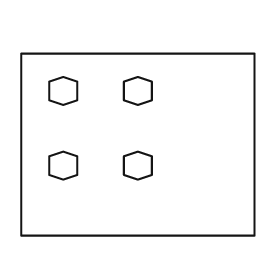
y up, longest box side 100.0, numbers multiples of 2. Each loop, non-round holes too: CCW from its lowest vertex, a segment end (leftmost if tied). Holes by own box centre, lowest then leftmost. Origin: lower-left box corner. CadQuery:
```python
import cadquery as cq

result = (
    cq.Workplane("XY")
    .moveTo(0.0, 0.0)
    .lineTo(100.0, 0.0)
    .lineTo(100.0, 78.0)
    .lineTo(0.0, 78.0)
    .close()
    .moveTo(18.0, 24.0)
    .lineTo(24.0, 26.0)
    .lineTo(24.0, 34.0)
    .lineTo(18.0, 36.0)
    .lineTo(12.0, 34.0)
    .lineTo(12.0, 26.0)
    .close()
    .moveTo(50.0, 24.0)
    .lineTo(56.0, 26.0)
    .lineTo(56.0, 34.0)
    .lineTo(50.0, 36.0)
    .lineTo(44.0, 34.0)
    .lineTo(44.0, 26.0)
    .close()
    .moveTo(18.0, 56.0)
    .lineTo(24.0, 58.0)
    .lineTo(24.0, 66.0)
    .lineTo(18.0, 68.0)
    .lineTo(12.0, 66.0)
    .lineTo(12.0, 58.0)
    .close()
    .moveTo(50.0, 56.0)
    .lineTo(56.0, 58.0)
    .lineTo(56.0, 66.0)
    .lineTo(50.0, 68.0)
    .lineTo(44.0, 66.0)
    .lineTo(44.0, 58.0)
    .close()
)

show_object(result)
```